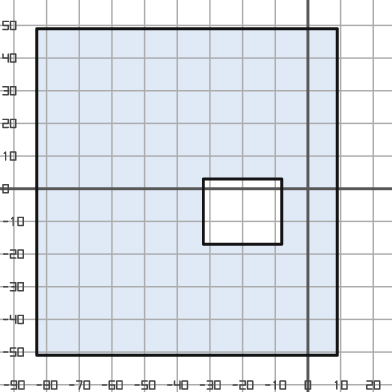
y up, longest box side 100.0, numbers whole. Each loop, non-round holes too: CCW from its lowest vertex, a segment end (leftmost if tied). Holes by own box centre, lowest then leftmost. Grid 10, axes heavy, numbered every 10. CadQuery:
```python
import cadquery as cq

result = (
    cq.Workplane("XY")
    .moveTo(-83.0, -51.0)
    .lineTo(9.0, -51.0)
    .lineTo(9.0, 49.0)
    .lineTo(-83.0, 49.0)
    .close()
    .moveTo(-32.0, -17.0)
    .lineTo(-8.0, -17.0)
    .lineTo(-8.0, 3.0)
    .lineTo(-32.0, 3.0)
    .close()
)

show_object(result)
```